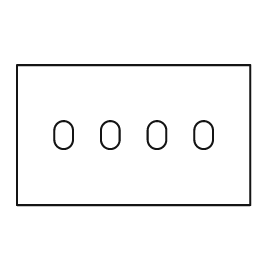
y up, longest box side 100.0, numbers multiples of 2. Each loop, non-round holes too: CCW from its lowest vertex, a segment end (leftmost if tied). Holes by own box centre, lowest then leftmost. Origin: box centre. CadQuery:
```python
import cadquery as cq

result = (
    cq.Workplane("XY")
    .moveTo(-50.0, -30.0)
    .lineTo(50.0, -30.0)
    .lineTo(50.0, 30.0)
    .lineTo(-50.0, 30.0)
    .close()
    .moveTo(-34.0, -2.0)
    .threePointArc((-30.0, -6.0), (-26.0, -2.0))
    .lineTo(-26.0, 2.0)
    .threePointArc((-30.0, 6.0), (-34.0, 2.0))
    .close()
    .moveTo(-14.0, -2.0)
    .threePointArc((-10.0, -6.0), (-6.0, -2.0))
    .lineTo(-6.0, 2.0)
    .threePointArc((-10.0, 6.0), (-14.0, 2.0))
    .close()
    .moveTo(6.0, -2.0)
    .threePointArc((10.0, -6.0), (14.0, -2.0))
    .lineTo(14.0, 2.0)
    .threePointArc((10.0, 6.0), (6.0, 2.0))
    .close()
    .moveTo(26.0, -2.0)
    .threePointArc((30.0, -6.0), (34.0, -2.0))
    .lineTo(34.0, 2.0)
    .threePointArc((30.0, 6.0), (26.0, 2.0))
    .close()
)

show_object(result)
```